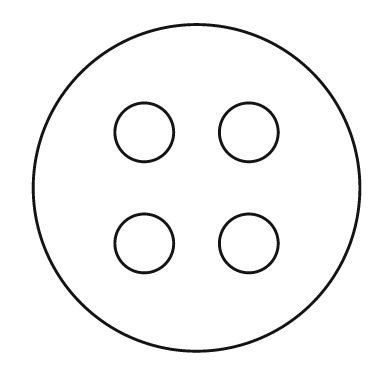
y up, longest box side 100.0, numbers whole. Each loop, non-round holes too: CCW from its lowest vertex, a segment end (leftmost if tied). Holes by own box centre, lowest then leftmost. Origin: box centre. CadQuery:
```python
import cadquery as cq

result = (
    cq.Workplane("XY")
    .moveTo(0.0, 0.0)
    .circle(50.0)
    .moveTo(-16.0, -17.0)
    .circle(9.0)
    .moveTo(16.0, -17.0)
    .circle(9.0)
    .moveTo(-16.0, 17.0)
    .circle(9.0)
    .moveTo(16.0, 17.0)
    .circle(9.0)
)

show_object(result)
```